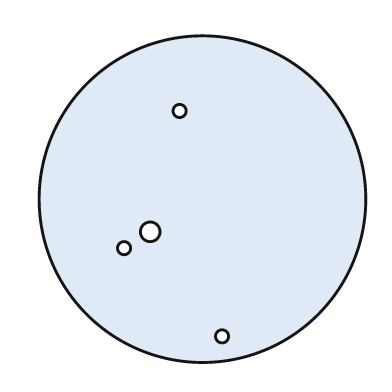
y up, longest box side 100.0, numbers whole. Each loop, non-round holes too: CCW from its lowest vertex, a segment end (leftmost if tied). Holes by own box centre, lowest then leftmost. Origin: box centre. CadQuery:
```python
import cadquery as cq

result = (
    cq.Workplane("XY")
    .moveTo(0.0, 0.0)
    .circle(50.0)
    .moveTo(6.0, -42.0)
    .circle(2.0)
    .moveTo(-24.0, -15.0)
    .circle(2.0)
    .moveTo(-16.0, -10.0)
    .circle(3.0)
    .moveTo(-7.0, 27.0)
    .circle(2.0)
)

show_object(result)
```